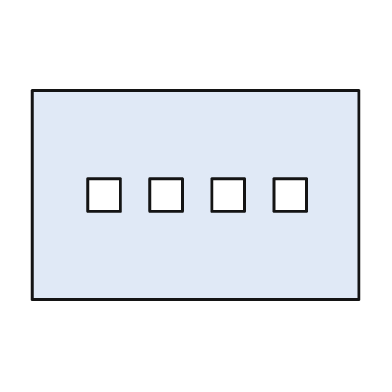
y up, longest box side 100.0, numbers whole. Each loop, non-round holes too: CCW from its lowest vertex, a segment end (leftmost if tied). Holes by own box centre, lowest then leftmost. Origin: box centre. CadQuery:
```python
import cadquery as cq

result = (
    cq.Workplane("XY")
    .moveTo(-50.0, -32.0)
    .lineTo(50.0, -32.0)
    .lineTo(50.0, 32.0)
    .lineTo(-50.0, 32.0)
    .close()
    .moveTo(-33.0, -5.0)
    .lineTo(-23.0, -5.0)
    .lineTo(-23.0, 5.0)
    .lineTo(-33.0, 5.0)
    .close()
    .moveTo(-14.0, -5.0)
    .lineTo(-4.0, -5.0)
    .lineTo(-4.0, 5.0)
    .lineTo(-14.0, 5.0)
    .close()
    .moveTo(5.0, -5.0)
    .lineTo(15.0, -5.0)
    .lineTo(15.0, 5.0)
    .lineTo(5.0, 5.0)
    .close()
    .moveTo(24.0, -5.0)
    .lineTo(34.0, -5.0)
    .lineTo(34.0, 5.0)
    .lineTo(24.0, 5.0)
    .close()
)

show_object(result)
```